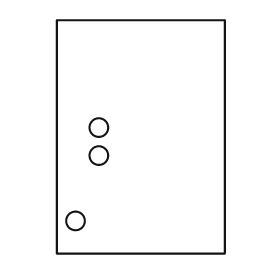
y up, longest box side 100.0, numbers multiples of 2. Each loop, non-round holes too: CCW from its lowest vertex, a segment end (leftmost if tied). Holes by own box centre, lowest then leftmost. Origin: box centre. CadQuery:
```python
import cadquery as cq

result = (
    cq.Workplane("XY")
    .moveTo(-36.0, -50.0)
    .lineTo(36.0, -50.0)
    .lineTo(36.0, 50.0)
    .lineTo(-36.0, 50.0)
    .close()
    .moveTo(-28.0, -36.0)
    .circle(4.0)
    .moveTo(-18.0, -8.0)
    .circle(4.0)
    .moveTo(-18.0, 4.0)
    .circle(4.0)
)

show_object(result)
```